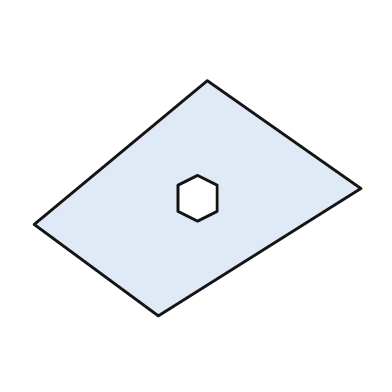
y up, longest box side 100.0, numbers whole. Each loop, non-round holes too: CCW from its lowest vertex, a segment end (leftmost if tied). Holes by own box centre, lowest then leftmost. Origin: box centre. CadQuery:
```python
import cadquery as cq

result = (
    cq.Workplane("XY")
    .moveTo(-12.0, -36.0)
    .lineTo(50.0, 3.0)
    .lineTo(3.0, 36.0)
    .lineTo(-50.0, -8.0)
    .close()
    .moveTo(0.0, -7.0)
    .lineTo(6.0, -4.0)
    .lineTo(6.0, 4.0)
    .lineTo(0.0, 7.0)
    .lineTo(-6.0, 4.0)
    .lineTo(-6.0, -4.0)
    .close()
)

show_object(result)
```